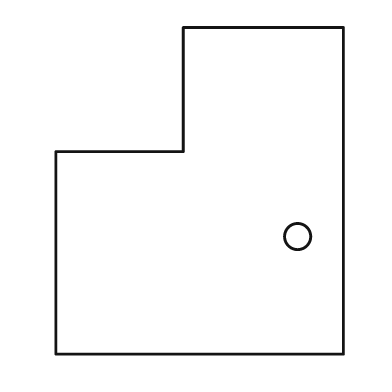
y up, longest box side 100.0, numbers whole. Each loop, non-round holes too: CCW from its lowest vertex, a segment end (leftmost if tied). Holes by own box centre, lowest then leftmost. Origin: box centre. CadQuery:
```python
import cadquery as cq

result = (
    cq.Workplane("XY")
    .moveTo(-44.0, -50.0)
    .lineTo(44.0, -50.0)
    .lineTo(44.0, 50.0)
    .lineTo(-5.0, 50.0)
    .lineTo(-5.0, 12.0)
    .lineTo(-44.0, 12.0)
    .close()
    .moveTo(30.0, -14.0)
    .circle(4.0)
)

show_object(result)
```